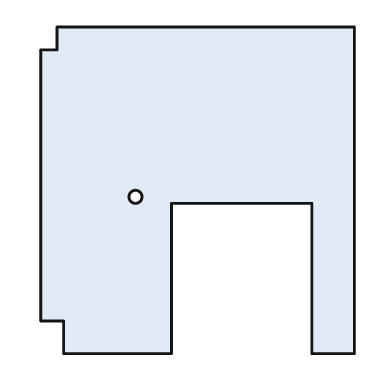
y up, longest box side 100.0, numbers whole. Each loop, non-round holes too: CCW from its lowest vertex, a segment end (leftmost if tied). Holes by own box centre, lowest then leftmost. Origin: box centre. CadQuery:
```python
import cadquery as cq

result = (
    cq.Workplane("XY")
    .moveTo(-41.0, -50.0)
    .lineTo(-8.0, -50.0)
    .lineTo(-8.0, -4.0)
    .lineTo(35.0, -4.0)
    .lineTo(35.0, -50.0)
    .lineTo(48.0, -50.0)
    .lineTo(48.0, 50.0)
    .lineTo(-43.0, 50.0)
    .lineTo(-43.0, 43.0)
    .lineTo(-48.0, 43.0)
    .lineTo(-48.0, -40.0)
    .lineTo(-41.0, -40.0)
    .close()
    .moveTo(-19.0, -2.0)
    .circle(2.0)
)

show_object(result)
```